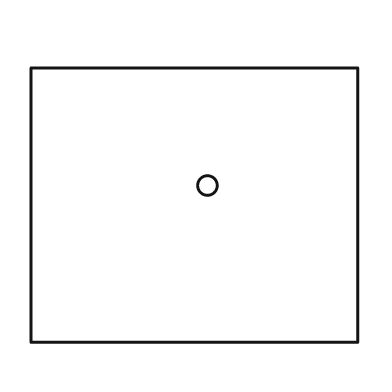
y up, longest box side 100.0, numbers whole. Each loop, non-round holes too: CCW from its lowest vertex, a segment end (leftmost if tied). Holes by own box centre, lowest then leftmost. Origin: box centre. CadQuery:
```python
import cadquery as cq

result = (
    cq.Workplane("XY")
    .moveTo(-50.0, -42.0)
    .lineTo(50.0, -42.0)
    .lineTo(50.0, 42.0)
    .lineTo(-50.0, 42.0)
    .close()
    .moveTo(4.0, 6.0)
    .circle(3.0)
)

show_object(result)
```